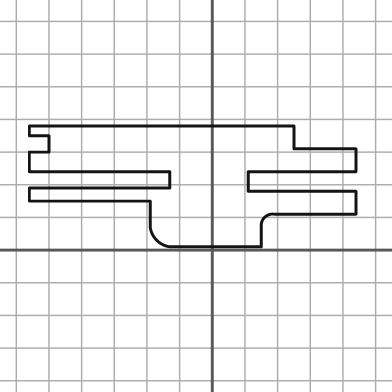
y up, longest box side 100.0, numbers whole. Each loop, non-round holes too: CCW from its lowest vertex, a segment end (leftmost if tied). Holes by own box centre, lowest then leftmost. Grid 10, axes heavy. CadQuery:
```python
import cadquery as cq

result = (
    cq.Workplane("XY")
    .moveTo(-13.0, 1.0)
    .lineTo(15.0, 1.0)
    .lineTo(15.0, 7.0)
    .threePointArc((16.0, 10.0), (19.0, 11.0))
    .lineTo(44.0, 11.0)
    .lineTo(44.0, 18.0)
    .lineTo(11.0, 18.0)
    .lineTo(11.0, 24.0)
    .lineTo(44.0, 24.0)
    .lineTo(44.0, 31.0)
    .lineTo(25.0, 31.0)
    .lineTo(25.0, 38.0)
    .lineTo(-56.0, 38.0)
    .lineTo(-56.0, 35.0)
    .lineTo(-50.0, 35.0)
    .lineTo(-50.0, 30.0)
    .lineTo(-56.0, 30.0)
    .lineTo(-56.0, 24.0)
    .lineTo(-13.0, 24.0)
    .lineTo(-13.0, 19.0)
    .lineTo(-56.0, 19.0)
    .lineTo(-56.0, 15.0)
    .lineTo(-19.0, 15.0)
    .lineTo(-19.0, 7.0)
    .threePointArc((-17.0, 3.0), (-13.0, 1.0))
    .close()
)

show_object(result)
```